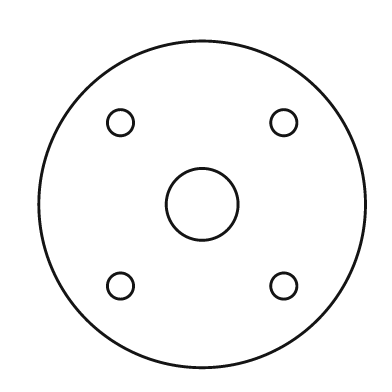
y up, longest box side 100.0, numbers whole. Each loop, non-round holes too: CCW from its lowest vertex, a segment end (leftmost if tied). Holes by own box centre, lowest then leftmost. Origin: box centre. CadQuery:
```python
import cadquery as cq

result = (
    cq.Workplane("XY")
    .moveTo(0.0, 0.0)
    .circle(50.0)
    .moveTo(-25.0, -25.0)
    .circle(4.0)
    .moveTo(25.0, -25.0)
    .circle(4.0)
    .moveTo(0.0, 0.0)
    .circle(11.0)
    .moveTo(-25.0, 25.0)
    .circle(4.0)
    .moveTo(25.0, 25.0)
    .circle(4.0)
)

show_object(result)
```